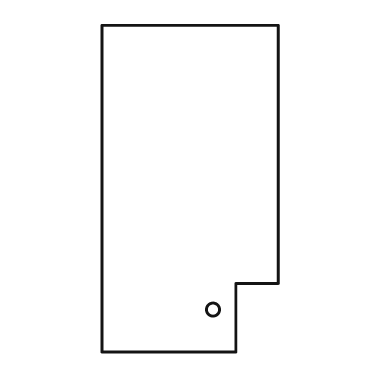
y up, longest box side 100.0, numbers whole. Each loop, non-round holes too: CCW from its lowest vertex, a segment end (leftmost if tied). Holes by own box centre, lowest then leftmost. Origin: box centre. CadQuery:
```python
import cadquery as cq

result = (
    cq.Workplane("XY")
    .moveTo(-27.0, -50.0)
    .lineTo(14.0, -50.0)
    .lineTo(14.0, -29.0)
    .lineTo(27.0, -29.0)
    .lineTo(27.0, 50.0)
    .lineTo(-27.0, 50.0)
    .close()
    .moveTo(7.0, -37.0)
    .circle(2.0)
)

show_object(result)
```